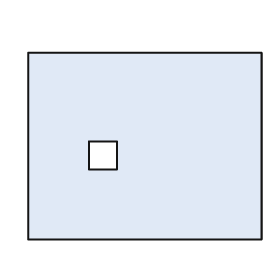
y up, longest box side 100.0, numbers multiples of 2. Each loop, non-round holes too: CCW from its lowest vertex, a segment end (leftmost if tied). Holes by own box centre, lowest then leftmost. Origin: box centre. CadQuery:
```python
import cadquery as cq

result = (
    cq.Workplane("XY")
    .moveTo(-50.0, -40.0)
    .lineTo(50.0, -40.0)
    .lineTo(50.0, 40.0)
    .lineTo(-50.0, 40.0)
    .close()
    .moveTo(-24.0, -10.0)
    .lineTo(-12.0, -10.0)
    .lineTo(-12.0, 2.0)
    .lineTo(-24.0, 2.0)
    .close()
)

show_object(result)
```